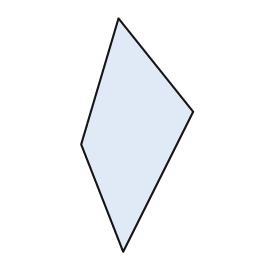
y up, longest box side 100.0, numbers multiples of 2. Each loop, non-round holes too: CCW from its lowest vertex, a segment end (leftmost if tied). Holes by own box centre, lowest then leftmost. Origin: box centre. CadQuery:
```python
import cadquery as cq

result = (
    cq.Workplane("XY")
    .moveTo(-6.0, -50.0)
    .lineTo(24.0, 10.0)
    .lineTo(-8.0, 50.0)
    .lineTo(-24.0, -4.0)
    .close()
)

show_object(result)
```